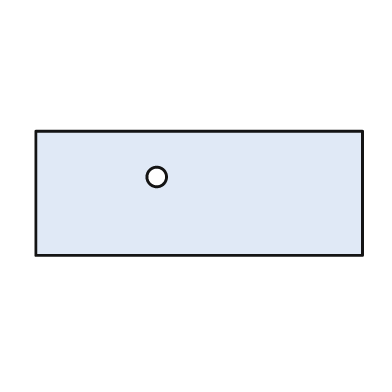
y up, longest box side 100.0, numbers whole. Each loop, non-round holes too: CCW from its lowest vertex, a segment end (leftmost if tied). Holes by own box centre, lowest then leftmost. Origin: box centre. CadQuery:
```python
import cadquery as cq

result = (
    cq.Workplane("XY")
    .moveTo(-50.0, -19.0)
    .lineTo(50.0, -19.0)
    .lineTo(50.0, 19.0)
    .lineTo(-50.0, 19.0)
    .close()
    .moveTo(-13.0, 5.0)
    .circle(3.0)
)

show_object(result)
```